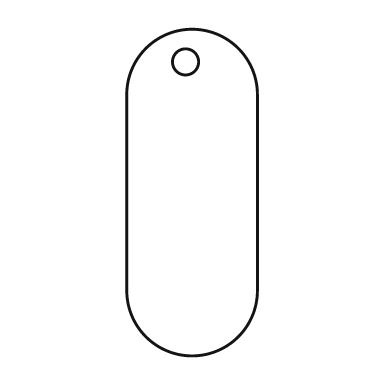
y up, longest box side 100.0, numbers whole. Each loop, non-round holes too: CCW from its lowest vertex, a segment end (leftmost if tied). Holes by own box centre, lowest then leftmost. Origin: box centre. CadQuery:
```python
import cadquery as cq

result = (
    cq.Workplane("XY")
    .moveTo(-20.0, -30.0)
    .threePointArc((0.0, -50.0), (20.0, -30.0))
    .lineTo(20.0, 30.0)
    .threePointArc((0.0, 50.0), (-20.0, 30.0))
    .close()
    .moveTo(-2.0, 40.0)
    .circle(4.0)
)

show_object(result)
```